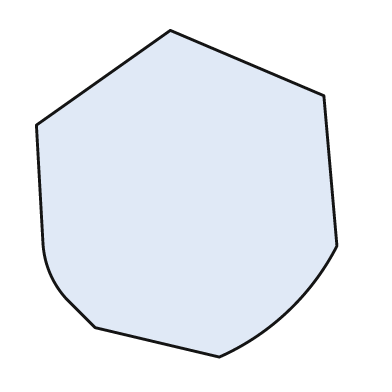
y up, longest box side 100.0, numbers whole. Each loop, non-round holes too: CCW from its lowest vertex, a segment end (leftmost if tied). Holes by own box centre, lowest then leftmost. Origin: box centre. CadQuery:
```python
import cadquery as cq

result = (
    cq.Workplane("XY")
    .moveTo(10.0, -50.0)
    .threePointArc((31.0, -36.0), (46.0, -16.0))
    .lineTo(42.0, 30.0)
    .lineTo(-5.0, 50.0)
    .lineTo(-46.0, 21.0)
    .lineTo(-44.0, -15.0)
    .threePointArc((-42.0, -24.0), (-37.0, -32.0))
    .lineTo(-28.0, -41.0)
    .close()
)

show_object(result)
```